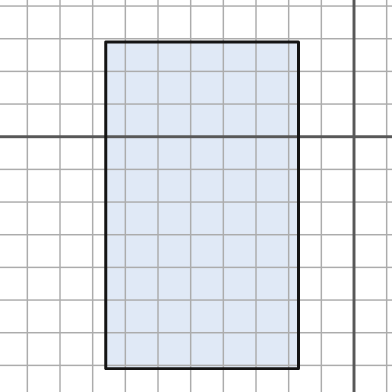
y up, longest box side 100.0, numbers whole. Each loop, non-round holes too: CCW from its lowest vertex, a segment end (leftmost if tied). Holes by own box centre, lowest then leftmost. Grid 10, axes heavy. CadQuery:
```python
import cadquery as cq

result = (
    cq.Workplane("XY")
    .moveTo(-76.0, -71.0)
    .lineTo(-17.0, -71.0)
    .lineTo(-17.0, 29.0)
    .lineTo(-76.0, 29.0)
    .close()
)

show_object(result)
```